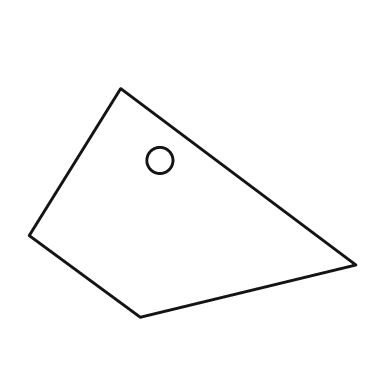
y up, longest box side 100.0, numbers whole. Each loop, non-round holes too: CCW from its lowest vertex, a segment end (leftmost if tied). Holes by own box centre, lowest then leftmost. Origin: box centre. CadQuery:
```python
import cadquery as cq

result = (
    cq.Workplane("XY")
    .moveTo(-16.0, -35.0)
    .lineTo(50.0, -19.0)
    .lineTo(-22.0, 35.0)
    .lineTo(-50.0, -10.0)
    .close()
    .moveTo(-10.0, 13.0)
    .circle(4.0)
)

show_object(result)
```